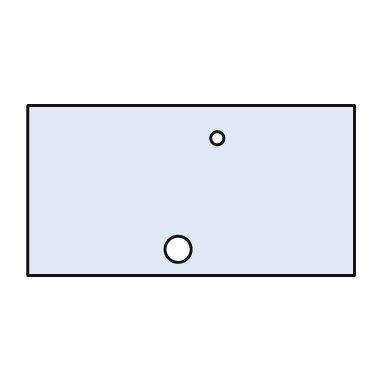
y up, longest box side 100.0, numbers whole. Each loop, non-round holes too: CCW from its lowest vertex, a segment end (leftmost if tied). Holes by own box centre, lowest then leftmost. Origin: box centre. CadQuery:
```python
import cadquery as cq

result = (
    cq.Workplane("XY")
    .moveTo(-50.0, -26.0)
    .lineTo(50.0, -26.0)
    .lineTo(50.0, 26.0)
    .lineTo(-50.0, 26.0)
    .close()
    .moveTo(-4.0, -18.0)
    .circle(4.0)
    .moveTo(8.0, 16.0)
    .circle(2.0)
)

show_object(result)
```